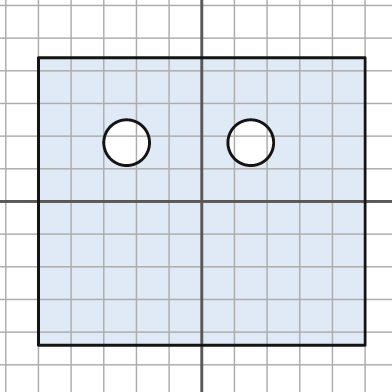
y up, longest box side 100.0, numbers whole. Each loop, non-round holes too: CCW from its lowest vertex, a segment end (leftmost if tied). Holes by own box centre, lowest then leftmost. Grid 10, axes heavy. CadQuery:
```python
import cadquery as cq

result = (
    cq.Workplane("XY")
    .moveTo(-50.0, -44.0)
    .lineTo(50.0, -44.0)
    .lineTo(50.0, 44.0)
    .lineTo(-50.0, 44.0)
    .close()
    .moveTo(-23.0, 18.0)
    .circle(7.0)
    .moveTo(15.0, 18.0)
    .circle(7.0)
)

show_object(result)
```